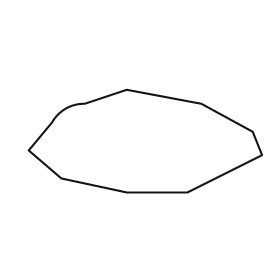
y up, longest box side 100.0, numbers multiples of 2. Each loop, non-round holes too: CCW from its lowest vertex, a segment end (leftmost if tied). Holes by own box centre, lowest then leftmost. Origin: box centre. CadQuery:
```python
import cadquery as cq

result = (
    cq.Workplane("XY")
    .moveTo(-8.0, -22.0)
    .lineTo(18.0, -22.0)
    .lineTo(50.0, -6.0)
    .lineTo(46.0, 4.0)
    .lineTo(24.0, 16.0)
    .lineTo(-8.0, 22.0)
    .lineTo(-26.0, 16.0)
    .threePointArc((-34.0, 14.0), (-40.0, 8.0))
    .lineTo(-50.0, -4.0)
    .lineTo(-36.0, -16.0)
    .close()
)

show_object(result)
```